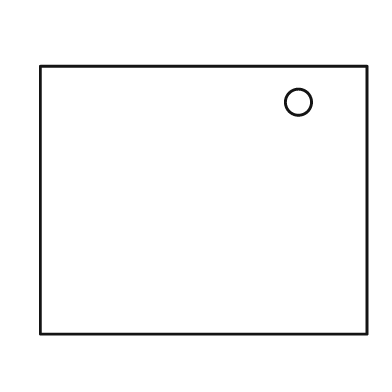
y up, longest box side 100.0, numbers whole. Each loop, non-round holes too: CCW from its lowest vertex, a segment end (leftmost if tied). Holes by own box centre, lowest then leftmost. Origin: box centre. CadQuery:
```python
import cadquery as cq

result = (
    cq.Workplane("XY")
    .moveTo(-50.0, -41.0)
    .lineTo(50.0, -41.0)
    .lineTo(50.0, 41.0)
    .lineTo(-50.0, 41.0)
    .close()
    .moveTo(29.0, 30.0)
    .circle(4.0)
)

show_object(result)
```